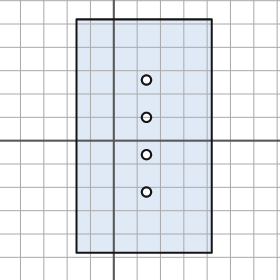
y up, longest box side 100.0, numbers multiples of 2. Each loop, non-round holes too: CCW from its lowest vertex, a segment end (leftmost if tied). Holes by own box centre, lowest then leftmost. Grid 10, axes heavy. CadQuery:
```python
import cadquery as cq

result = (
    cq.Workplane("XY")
    .moveTo(-16.0, -48.0)
    .lineTo(42.0, -48.0)
    .lineTo(42.0, 52.0)
    .lineTo(-16.0, 52.0)
    .close()
    .moveTo(14.0, -22.0)
    .circle(2.0)
    .moveTo(14.0, -6.0)
    .circle(2.0)
    .moveTo(14.0, 10.0)
    .circle(2.0)
    .moveTo(14.0, 26.0)
    .circle(2.0)
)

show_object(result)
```